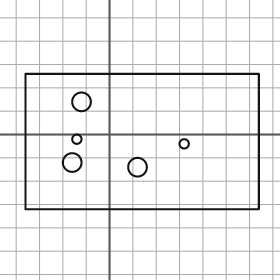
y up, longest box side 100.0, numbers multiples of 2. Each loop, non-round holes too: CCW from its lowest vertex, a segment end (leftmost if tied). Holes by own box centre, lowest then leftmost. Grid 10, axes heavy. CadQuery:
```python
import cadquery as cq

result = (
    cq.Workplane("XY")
    .moveTo(-36.0, -32.0)
    .lineTo(64.0, -32.0)
    .lineTo(64.0, 26.0)
    .lineTo(-36.0, 26.0)
    .close()
    .moveTo(12.0, -14.0)
    .circle(4.0)
    .moveTo(-16.0, -12.0)
    .circle(4.0)
    .moveTo(32.0, -4.0)
    .circle(2.0)
    .moveTo(-14.0, -2.0)
    .circle(2.0)
    .moveTo(-12.0, 14.0)
    .circle(4.0)
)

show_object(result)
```